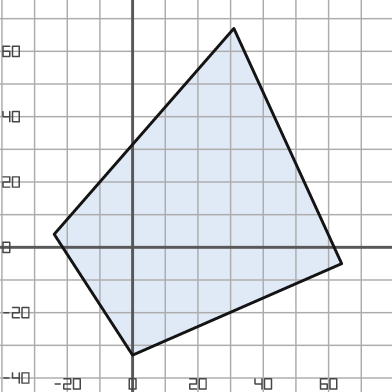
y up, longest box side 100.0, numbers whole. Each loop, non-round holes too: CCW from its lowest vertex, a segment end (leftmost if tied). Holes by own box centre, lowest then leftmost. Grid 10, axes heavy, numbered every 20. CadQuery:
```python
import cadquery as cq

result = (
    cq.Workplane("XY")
    .moveTo(0.0, -33.0)
    .lineTo(64.0, -5.0)
    .lineTo(31.0, 67.0)
    .lineTo(-24.0, 4.0)
    .close()
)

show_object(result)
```